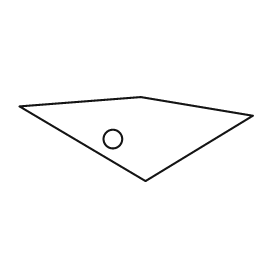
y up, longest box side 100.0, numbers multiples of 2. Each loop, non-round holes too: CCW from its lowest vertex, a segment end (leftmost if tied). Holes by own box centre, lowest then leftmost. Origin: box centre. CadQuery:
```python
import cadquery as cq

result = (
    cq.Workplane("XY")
    .moveTo(4.0, -18.0)
    .lineTo(50.0, 10.0)
    .lineTo(2.0, 18.0)
    .lineTo(-50.0, 14.0)
    .close()
    .moveTo(-10.0, 0.0)
    .circle(4.0)
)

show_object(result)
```